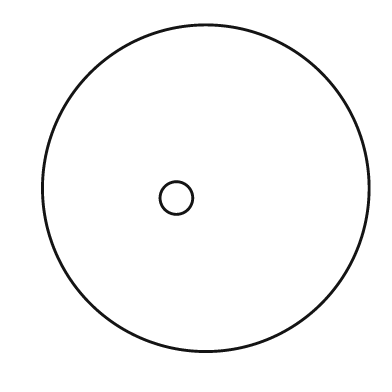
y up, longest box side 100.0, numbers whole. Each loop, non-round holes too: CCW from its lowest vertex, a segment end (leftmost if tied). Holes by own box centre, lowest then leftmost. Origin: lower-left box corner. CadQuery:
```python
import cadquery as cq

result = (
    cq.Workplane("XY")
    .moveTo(50.0, 50.0)
    .circle(50.0)
    .moveTo(41.0, 47.0)
    .circle(5.0)
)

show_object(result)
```